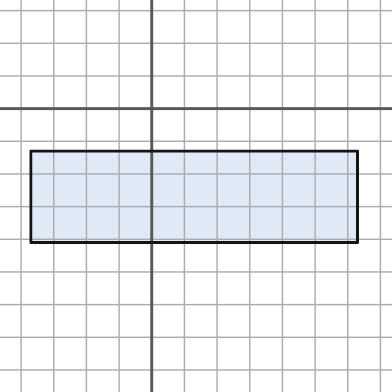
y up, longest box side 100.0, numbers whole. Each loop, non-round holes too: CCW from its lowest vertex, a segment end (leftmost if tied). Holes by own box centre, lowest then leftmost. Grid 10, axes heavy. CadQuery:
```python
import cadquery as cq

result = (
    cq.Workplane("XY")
    .moveTo(-37.0, -41.0)
    .lineTo(63.0, -41.0)
    .lineTo(63.0, -13.0)
    .lineTo(-37.0, -13.0)
    .close()
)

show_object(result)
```